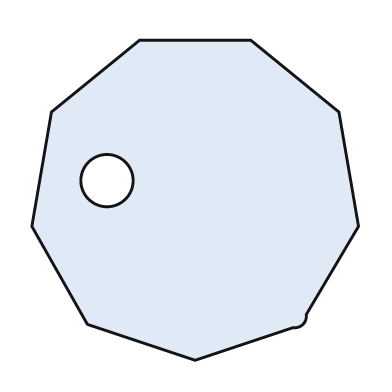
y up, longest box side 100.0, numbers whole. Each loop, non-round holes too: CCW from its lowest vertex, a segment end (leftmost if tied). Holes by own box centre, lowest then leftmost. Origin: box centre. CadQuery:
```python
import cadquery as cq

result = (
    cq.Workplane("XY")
    .moveTo(0.0, -49.0)
    .lineTo(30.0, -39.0)
    .threePointArc((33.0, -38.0), (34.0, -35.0))
    .lineTo(50.0, -8.0)
    .lineTo(44.0, 27.0)
    .lineTo(17.0, 49.0)
    .lineTo(-17.0, 49.0)
    .lineTo(-44.0, 27.0)
    .lineTo(-50.0, -8.0)
    .lineTo(-33.0, -38.0)
    .close()
    .moveTo(-27.0, 6.0)
    .circle(8.0)
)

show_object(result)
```